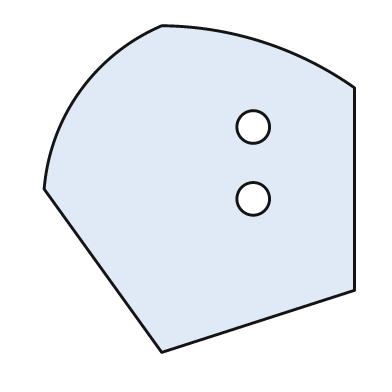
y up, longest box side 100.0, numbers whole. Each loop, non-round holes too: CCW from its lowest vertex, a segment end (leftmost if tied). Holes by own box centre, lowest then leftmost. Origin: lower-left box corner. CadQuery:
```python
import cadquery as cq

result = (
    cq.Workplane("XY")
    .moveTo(36.0, 0.0)
    .lineTo(95.0, 19.0)
    .lineTo(95.0, 81.0)
    .threePointArc((67.0, 95.0), (36.0, 100.0))
    .threePointArc((11.0, 80.0), (0.0, 50.0))
    .close()
    .moveTo(64.0, 47.0)
    .circle(5.0)
    .moveTo(64.0, 69.0)
    .circle(5.0)
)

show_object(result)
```